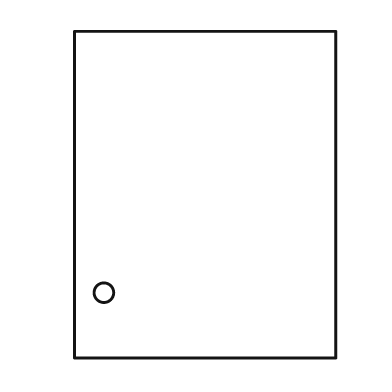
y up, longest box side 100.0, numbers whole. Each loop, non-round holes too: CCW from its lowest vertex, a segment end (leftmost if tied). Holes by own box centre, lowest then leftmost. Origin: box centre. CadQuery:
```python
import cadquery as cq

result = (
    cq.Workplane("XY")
    .moveTo(-40.0, -50.0)
    .lineTo(40.0, -50.0)
    .lineTo(40.0, 50.0)
    .lineTo(-40.0, 50.0)
    .close()
    .moveTo(-31.0, -30.0)
    .circle(3.0)
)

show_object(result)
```